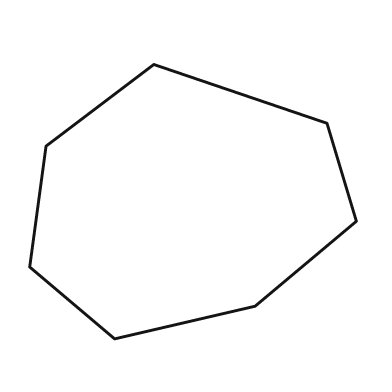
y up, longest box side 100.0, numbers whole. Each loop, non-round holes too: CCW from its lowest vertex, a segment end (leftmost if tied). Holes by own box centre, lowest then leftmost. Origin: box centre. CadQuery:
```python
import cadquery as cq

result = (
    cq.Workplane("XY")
    .moveTo(-24.0, -42.0)
    .lineTo(19.0, -32.0)
    .lineTo(50.0, -6.0)
    .lineTo(41.0, 24.0)
    .lineTo(-12.0, 42.0)
    .lineTo(-45.0, 17.0)
    .lineTo(-50.0, -20.0)
    .close()
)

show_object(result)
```